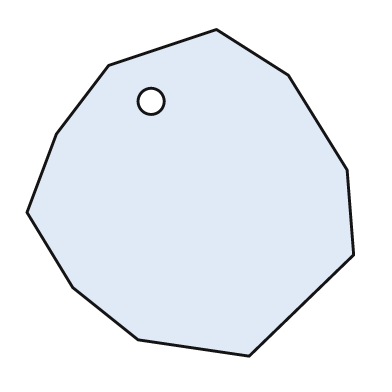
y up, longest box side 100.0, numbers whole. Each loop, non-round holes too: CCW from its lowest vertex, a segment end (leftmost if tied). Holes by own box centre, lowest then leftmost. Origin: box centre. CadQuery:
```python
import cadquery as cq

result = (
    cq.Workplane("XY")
    .moveTo(18.0, -50.0)
    .lineTo(50.0, -19.0)
    .lineTo(48.0, 7.0)
    .lineTo(30.0, 36.0)
    .lineTo(8.0, 50.0)
    .lineTo(-25.0, 39.0)
    .lineTo(-41.0, 18.0)
    .lineTo(-50.0, -6.0)
    .lineTo(-36.0, -29.0)
    .lineTo(-16.0, -45.0)
    .close()
    .moveTo(-12.0, 28.0)
    .circle(4.0)
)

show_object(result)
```